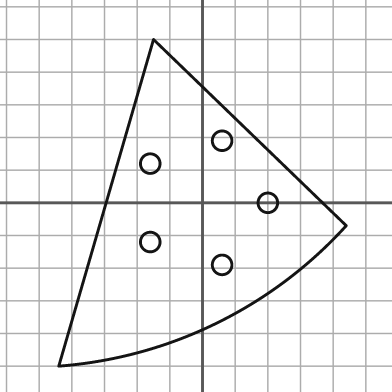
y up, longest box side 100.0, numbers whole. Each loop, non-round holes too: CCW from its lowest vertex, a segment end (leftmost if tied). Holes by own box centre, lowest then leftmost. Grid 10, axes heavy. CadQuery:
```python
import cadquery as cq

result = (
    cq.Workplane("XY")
    .moveTo(-44.0, -50.0)
    .threePointArc((4.0, -37.0), (44.0, -7.0))
    .lineTo(-15.0, 50.0)
    .close()
    .moveTo(6.0, -19.0)
    .circle(3.0)
    .moveTo(-16.0, -12.0)
    .circle(3.0)
    .moveTo(20.0, 0.0)
    .circle(3.0)
    .moveTo(-16.0, 12.0)
    .circle(3.0)
    .moveTo(6.0, 19.0)
    .circle(3.0)
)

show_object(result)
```